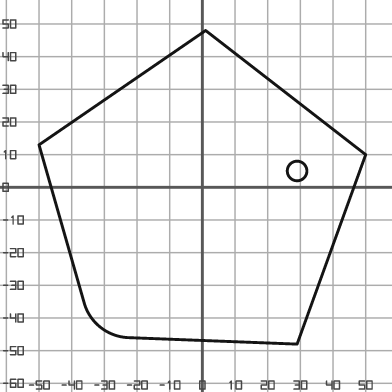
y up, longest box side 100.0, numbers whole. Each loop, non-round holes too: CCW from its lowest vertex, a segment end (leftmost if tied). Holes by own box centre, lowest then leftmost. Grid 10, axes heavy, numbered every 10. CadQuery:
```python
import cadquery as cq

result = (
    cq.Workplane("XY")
    .moveTo(29.0, -48.0)
    .lineTo(50.0, 10.0)
    .lineTo(1.0, 48.0)
    .lineTo(-50.0, 13.0)
    .lineTo(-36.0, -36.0)
    .threePointArc((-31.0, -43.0), (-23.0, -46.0))
    .close()
    .moveTo(29.0, 5.0)
    .circle(3.0)
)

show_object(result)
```